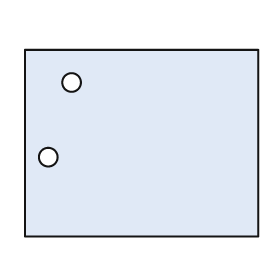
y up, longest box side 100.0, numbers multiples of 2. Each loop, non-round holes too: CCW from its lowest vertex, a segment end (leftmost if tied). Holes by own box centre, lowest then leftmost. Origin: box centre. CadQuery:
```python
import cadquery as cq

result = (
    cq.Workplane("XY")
    .moveTo(-50.0, -40.0)
    .lineTo(50.0, -40.0)
    .lineTo(50.0, 40.0)
    .lineTo(-50.0, 40.0)
    .close()
    .moveTo(-40.0, -6.0)
    .circle(4.0)
    .moveTo(-30.0, 26.0)
    .circle(4.0)
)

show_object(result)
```